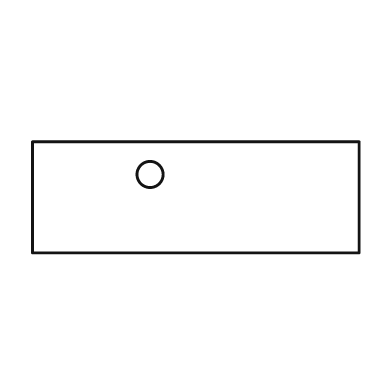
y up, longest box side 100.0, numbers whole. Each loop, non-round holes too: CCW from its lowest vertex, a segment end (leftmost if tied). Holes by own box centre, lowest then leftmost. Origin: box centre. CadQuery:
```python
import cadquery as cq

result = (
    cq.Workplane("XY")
    .moveTo(-50.0, -17.0)
    .lineTo(50.0, -17.0)
    .lineTo(50.0, 17.0)
    .lineTo(-50.0, 17.0)
    .close()
    .moveTo(-14.0, 7.0)
    .circle(4.0)
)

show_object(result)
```